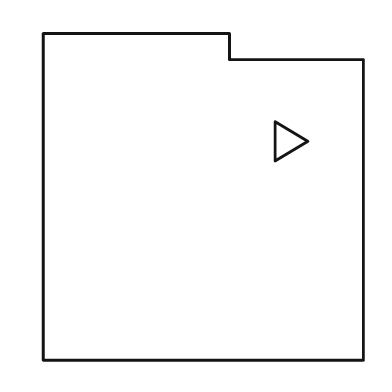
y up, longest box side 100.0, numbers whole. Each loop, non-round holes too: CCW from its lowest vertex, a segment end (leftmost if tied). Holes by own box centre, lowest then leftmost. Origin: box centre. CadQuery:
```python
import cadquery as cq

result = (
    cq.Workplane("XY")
    .moveTo(-49.0, -50.0)
    .lineTo(49.0, -50.0)
    .lineTo(49.0, 42.0)
    .lineTo(8.0, 42.0)
    .lineTo(8.0, 50.0)
    .lineTo(-49.0, 50.0)
    .close()
    .moveTo(22.0, 11.0)
    .lineTo(32.0, 17.0)
    .lineTo(22.0, 23.0)
    .close()
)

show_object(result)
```